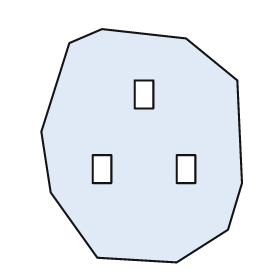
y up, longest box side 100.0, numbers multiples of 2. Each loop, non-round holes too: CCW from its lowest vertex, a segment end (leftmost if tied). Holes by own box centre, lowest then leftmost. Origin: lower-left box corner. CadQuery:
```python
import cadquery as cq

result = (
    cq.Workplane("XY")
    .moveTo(58.0, 0.0)
    .lineTo(80.0, 14.0)
    .lineTo(86.0, 34.0)
    .lineTo(84.0, 78.0)
    .lineTo(62.0, 96.0)
    .lineTo(26.0, 100.0)
    .lineTo(12.0, 94.0)
    .lineTo(0.0, 56.0)
    .lineTo(4.0, 30.0)
    .lineTo(24.0, 2.0)
    .close()
    .moveTo(22.0, 34.0)
    .lineTo(30.0, 34.0)
    .lineTo(30.0, 46.0)
    .lineTo(22.0, 46.0)
    .close()
    .moveTo(58.0, 34.0)
    .lineTo(66.0, 34.0)
    .lineTo(66.0, 46.0)
    .lineTo(58.0, 46.0)
    .close()
    .moveTo(40.0, 66.0)
    .lineTo(48.0, 66.0)
    .lineTo(48.0, 78.0)
    .lineTo(40.0, 78.0)
    .close()
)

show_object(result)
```